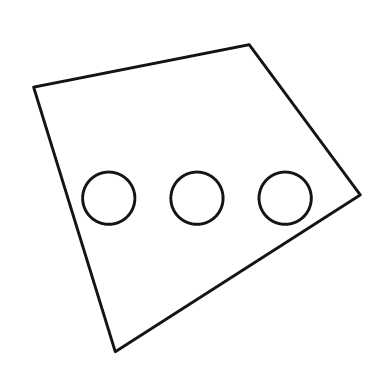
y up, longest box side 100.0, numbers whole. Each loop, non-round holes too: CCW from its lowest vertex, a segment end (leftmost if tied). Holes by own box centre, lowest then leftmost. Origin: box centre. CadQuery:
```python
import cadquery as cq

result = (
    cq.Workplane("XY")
    .moveTo(-25.0, -47.0)
    .lineTo(50.0, 1.0)
    .lineTo(16.0, 47.0)
    .lineTo(-50.0, 34.0)
    .close()
    .moveTo(-27.0, 0.0)
    .circle(8.0)
    .moveTo(0.0, 0.0)
    .circle(8.0)
    .moveTo(27.0, 0.0)
    .circle(8.0)
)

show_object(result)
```